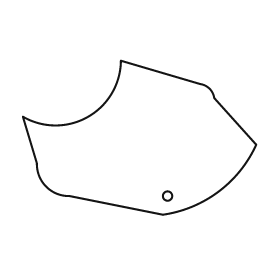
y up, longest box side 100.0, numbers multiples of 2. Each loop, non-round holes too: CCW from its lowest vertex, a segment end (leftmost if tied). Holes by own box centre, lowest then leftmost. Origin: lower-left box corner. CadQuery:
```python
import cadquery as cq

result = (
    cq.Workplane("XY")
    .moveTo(60.0, 0.0)
    .threePointArc((84.0, 10.0), (100.0, 30.0))
    .lineTo(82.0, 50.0)
    .threePointArc((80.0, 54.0), (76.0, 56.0))
    .lineTo(42.0, 66.0)
    .threePointArc((28.0, 42.0), (0.0, 42.0))
    .lineTo(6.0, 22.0)
    .threePointArc((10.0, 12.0), (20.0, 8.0))
    .close()
    .moveTo(62.0, 8.0)
    .circle(2.0)
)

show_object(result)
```